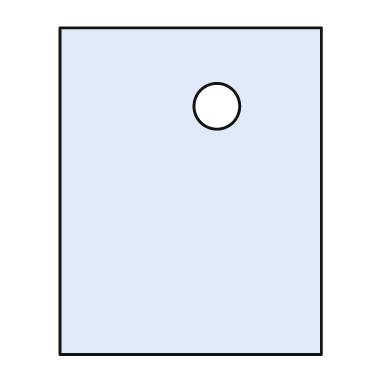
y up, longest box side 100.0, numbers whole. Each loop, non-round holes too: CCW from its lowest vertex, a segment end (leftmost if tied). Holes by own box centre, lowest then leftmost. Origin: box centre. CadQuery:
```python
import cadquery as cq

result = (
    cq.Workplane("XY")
    .moveTo(-40.0, -50.0)
    .lineTo(40.0, -50.0)
    .lineTo(40.0, 50.0)
    .lineTo(-40.0, 50.0)
    .close()
    .moveTo(8.0, 26.0)
    .circle(7.0)
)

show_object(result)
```